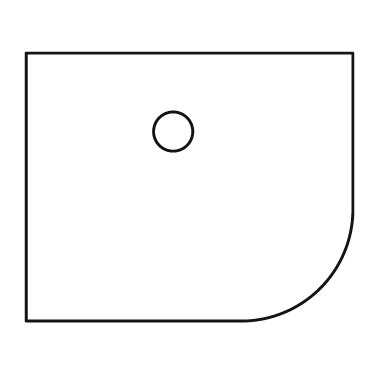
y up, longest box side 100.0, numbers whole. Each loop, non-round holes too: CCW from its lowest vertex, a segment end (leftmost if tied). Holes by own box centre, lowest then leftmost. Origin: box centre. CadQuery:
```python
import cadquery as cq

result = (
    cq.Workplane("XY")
    .moveTo(-50.0, -41.0)
    .lineTo(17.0, -41.0)
    .threePointArc((40.0, -31.0), (50.0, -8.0))
    .lineTo(50.0, 41.0)
    .lineTo(-50.0, 41.0)
    .close()
    .moveTo(-5.0, 17.0)
    .circle(6.0)
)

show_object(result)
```